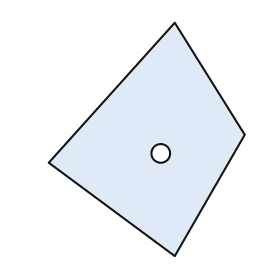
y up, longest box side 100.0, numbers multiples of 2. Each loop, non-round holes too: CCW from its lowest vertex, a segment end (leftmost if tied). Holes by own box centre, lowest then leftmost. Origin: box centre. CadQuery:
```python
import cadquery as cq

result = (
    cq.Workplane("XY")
    .moveTo(12.0, -50.0)
    .lineTo(42.0, 2.0)
    .lineTo(12.0, 50.0)
    .lineTo(-42.0, -10.0)
    .close()
    .moveTo(6.0, -6.0)
    .circle(4.0)
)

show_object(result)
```